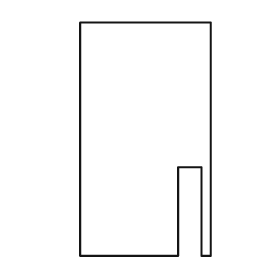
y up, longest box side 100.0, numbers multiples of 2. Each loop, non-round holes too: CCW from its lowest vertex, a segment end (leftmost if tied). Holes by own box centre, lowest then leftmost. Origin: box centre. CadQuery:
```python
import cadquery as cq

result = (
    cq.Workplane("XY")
    .moveTo(-28.0, -50.0)
    .lineTo(14.0, -50.0)
    .lineTo(14.0, -12.0)
    .lineTo(24.0, -12.0)
    .lineTo(24.0, -50.0)
    .lineTo(28.0, -50.0)
    .lineTo(28.0, 50.0)
    .lineTo(-28.0, 50.0)
    .close()
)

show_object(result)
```